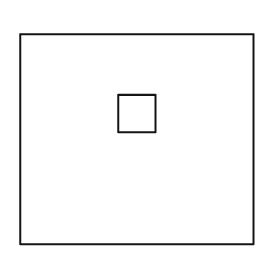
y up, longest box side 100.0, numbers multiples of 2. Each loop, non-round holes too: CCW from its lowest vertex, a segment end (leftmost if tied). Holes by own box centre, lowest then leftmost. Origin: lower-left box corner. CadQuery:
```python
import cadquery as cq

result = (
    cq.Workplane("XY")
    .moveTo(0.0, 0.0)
    .lineTo(100.0, 0.0)
    .lineTo(100.0, 90.0)
    .lineTo(0.0, 90.0)
    .close()
    .moveTo(42.0, 48.0)
    .lineTo(58.0, 48.0)
    .lineTo(58.0, 64.0)
    .lineTo(42.0, 64.0)
    .close()
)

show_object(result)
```